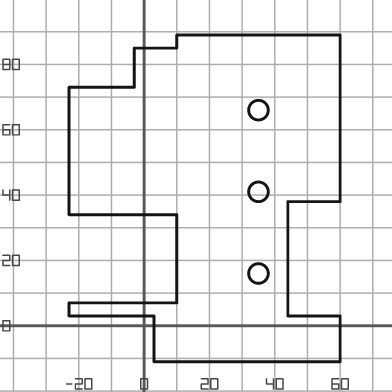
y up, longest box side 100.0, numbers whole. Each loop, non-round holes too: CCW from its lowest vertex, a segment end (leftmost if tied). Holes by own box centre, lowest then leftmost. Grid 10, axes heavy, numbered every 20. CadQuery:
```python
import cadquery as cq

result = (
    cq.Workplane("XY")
    .moveTo(3.0, -11.0)
    .lineTo(60.0, -11.0)
    .lineTo(60.0, 3.0)
    .lineTo(44.0, 3.0)
    .lineTo(44.0, 38.0)
    .lineTo(60.0, 38.0)
    .lineTo(60.0, 89.0)
    .lineTo(10.0, 89.0)
    .lineTo(10.0, 85.0)
    .lineTo(-3.0, 85.0)
    .lineTo(-3.0, 73.0)
    .lineTo(-23.0, 73.0)
    .lineTo(-23.0, 34.0)
    .lineTo(10.0, 34.0)
    .lineTo(10.0, 7.0)
    .lineTo(-23.0, 7.0)
    .lineTo(-23.0, 3.0)
    .lineTo(3.0, 3.0)
    .close()
    .moveTo(35.0, 16.0)
    .circle(3.0)
    .moveTo(35.0, 41.0)
    .circle(3.0)
    .moveTo(35.0, 66.0)
    .circle(3.0)
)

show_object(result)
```